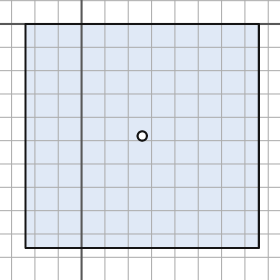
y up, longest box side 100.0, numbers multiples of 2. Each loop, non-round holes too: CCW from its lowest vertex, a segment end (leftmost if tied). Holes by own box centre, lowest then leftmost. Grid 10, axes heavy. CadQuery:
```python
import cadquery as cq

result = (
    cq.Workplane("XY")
    .moveTo(-24.0, -96.0)
    .lineTo(76.0, -96.0)
    .lineTo(76.0, 0.0)
    .lineTo(-24.0, 0.0)
    .close()
    .moveTo(26.0, -48.0)
    .circle(2.0)
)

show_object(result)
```